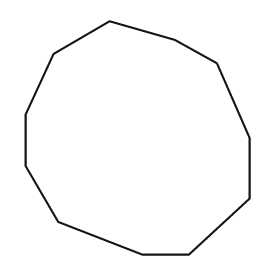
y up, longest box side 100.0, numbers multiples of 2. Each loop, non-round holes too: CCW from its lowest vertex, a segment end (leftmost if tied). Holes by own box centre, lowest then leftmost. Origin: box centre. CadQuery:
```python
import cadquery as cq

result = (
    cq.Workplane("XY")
    .moveTo(2.0, -50.0)
    .lineTo(22.0, -50.0)
    .lineTo(48.0, -26.0)
    .lineTo(48.0, 0.0)
    .lineTo(34.0, 32.0)
    .lineTo(16.0, 42.0)
    .lineTo(-12.0, 50.0)
    .lineTo(-36.0, 36.0)
    .lineTo(-48.0, 10.0)
    .lineTo(-48.0, -12.0)
    .lineTo(-34.0, -36.0)
    .close()
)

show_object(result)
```